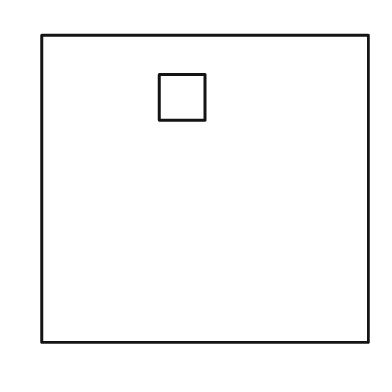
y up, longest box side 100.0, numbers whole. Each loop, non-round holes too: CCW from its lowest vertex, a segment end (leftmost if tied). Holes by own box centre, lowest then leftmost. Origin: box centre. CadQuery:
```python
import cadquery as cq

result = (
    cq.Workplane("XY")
    .moveTo(-50.0, -47.0)
    .lineTo(50.0, -47.0)
    .lineTo(50.0, 47.0)
    .lineTo(-50.0, 47.0)
    .close()
    .moveTo(-14.0, 21.0)
    .lineTo(0.0, 21.0)
    .lineTo(0.0, 35.0)
    .lineTo(-14.0, 35.0)
    .close()
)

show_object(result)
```